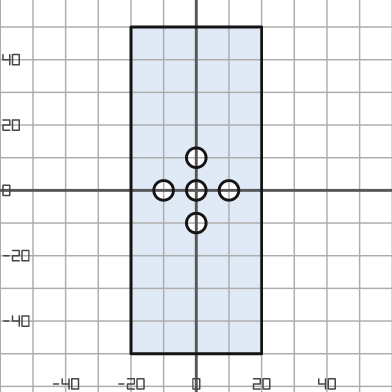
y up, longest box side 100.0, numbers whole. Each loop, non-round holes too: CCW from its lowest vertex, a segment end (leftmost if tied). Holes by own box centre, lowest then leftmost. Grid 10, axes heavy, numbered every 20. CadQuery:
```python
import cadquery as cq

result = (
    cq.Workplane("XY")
    .moveTo(-20.0, -50.0)
    .lineTo(20.0, -50.0)
    .lineTo(20.0, 50.0)
    .lineTo(-20.0, 50.0)
    .close()
    .moveTo(0.0, -10.0)
    .circle(3.0)
    .moveTo(-10.0, 0.0)
    .circle(3.0)
    .moveTo(0.0, 0.0)
    .circle(3.0)
    .moveTo(10.0, 0.0)
    .circle(3.0)
    .moveTo(0.0, 10.0)
    .circle(3.0)
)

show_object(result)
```